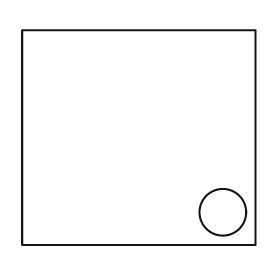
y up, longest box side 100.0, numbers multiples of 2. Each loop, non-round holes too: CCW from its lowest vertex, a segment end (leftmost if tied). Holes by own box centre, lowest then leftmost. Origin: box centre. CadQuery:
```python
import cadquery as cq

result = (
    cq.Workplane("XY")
    .moveTo(-50.0, -46.0)
    .lineTo(50.0, -46.0)
    .lineTo(50.0, 46.0)
    .lineTo(-50.0, 46.0)
    .close()
    .moveTo(36.0, -32.0)
    .circle(10.0)
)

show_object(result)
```